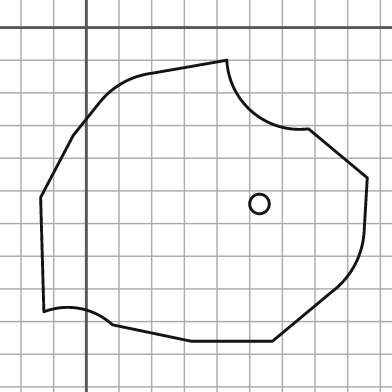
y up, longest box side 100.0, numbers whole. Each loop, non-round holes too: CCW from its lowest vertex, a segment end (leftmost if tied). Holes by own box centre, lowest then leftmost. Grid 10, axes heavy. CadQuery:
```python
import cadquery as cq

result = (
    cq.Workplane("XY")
    .moveTo(32.0, -96.0)
    .lineTo(57.0, -96.0)
    .lineTo(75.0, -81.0)
    .threePointArc((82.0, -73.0), (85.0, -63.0))
    .lineTo(86.0, -46.0)
    .lineTo(68.0, -31.0)
    .threePointArc((51.0, -26.0), (43.0, -10.0))
    .lineTo(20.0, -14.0)
    .threePointArc((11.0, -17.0), (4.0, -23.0))
    .lineTo(-4.0, -33.0)
    .lineTo(-14.0, -52.0)
    .lineTo(-13.0, -87.0)
    .threePointArc((-2.0, -86.0), (8.0, -91.0))
    .close()
    .moveTo(53.0, -54.0)
    .circle(3.0)
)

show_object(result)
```